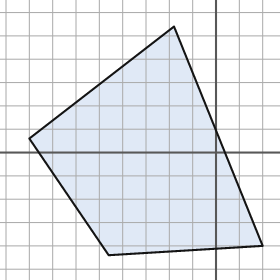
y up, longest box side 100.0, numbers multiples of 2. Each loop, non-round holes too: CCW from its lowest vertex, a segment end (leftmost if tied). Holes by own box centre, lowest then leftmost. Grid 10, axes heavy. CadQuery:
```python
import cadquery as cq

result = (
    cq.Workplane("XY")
    .moveTo(-46.0, -44.0)
    .lineTo(20.0, -40.0)
    .lineTo(-18.0, 54.0)
    .lineTo(-80.0, 6.0)
    .close()
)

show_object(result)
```